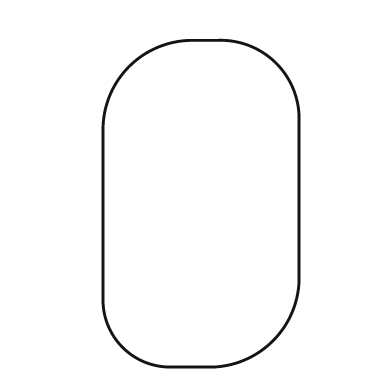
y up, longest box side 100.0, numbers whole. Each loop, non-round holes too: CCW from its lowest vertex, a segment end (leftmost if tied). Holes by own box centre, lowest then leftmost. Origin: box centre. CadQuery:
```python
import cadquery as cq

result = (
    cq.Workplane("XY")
    .moveTo(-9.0, -50.0)
    .lineTo(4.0, -50.0)
    .threePointArc((22.0, -42.0), (30.0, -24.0))
    .lineTo(30.0, 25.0)
    .threePointArc((23.0, 43.0), (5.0, 50.0))
    .lineTo(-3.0, 50.0)
    .threePointArc((-22.0, 42.0), (-30.0, 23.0))
    .lineTo(-30.0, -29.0)
    .threePointArc((-24.0, -44.0), (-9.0, -50.0))
    .close()
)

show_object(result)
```